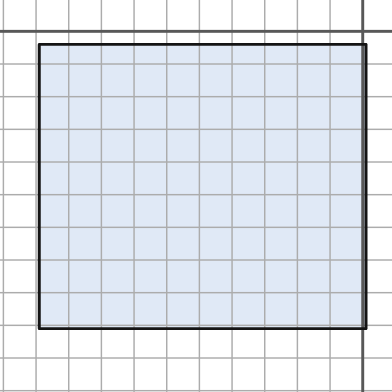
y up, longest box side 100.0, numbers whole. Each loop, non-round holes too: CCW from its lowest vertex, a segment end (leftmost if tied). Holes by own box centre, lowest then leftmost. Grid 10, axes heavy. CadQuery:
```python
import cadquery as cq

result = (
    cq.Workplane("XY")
    .moveTo(-99.0, -91.0)
    .lineTo(1.0, -91.0)
    .lineTo(1.0, -4.0)
    .lineTo(-99.0, -4.0)
    .close()
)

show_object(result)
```